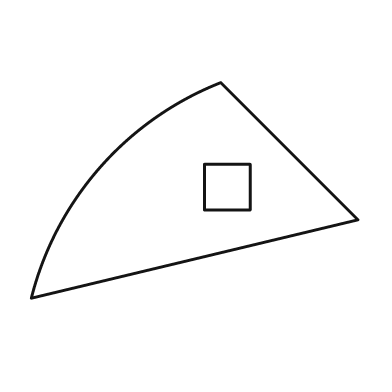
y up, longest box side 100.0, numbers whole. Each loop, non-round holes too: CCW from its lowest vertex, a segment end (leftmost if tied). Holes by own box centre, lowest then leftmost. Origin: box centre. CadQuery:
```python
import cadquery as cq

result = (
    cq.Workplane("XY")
    .moveTo(-50.0, -33.0)
    .lineTo(50.0, -9.0)
    .lineTo(8.0, 33.0)
    .threePointArc((-29.0, 7.0), (-50.0, -33.0))
    .close()
    .moveTo(3.0, -6.0)
    .lineTo(17.0, -6.0)
    .lineTo(17.0, 8.0)
    .lineTo(3.0, 8.0)
    .close()
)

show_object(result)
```